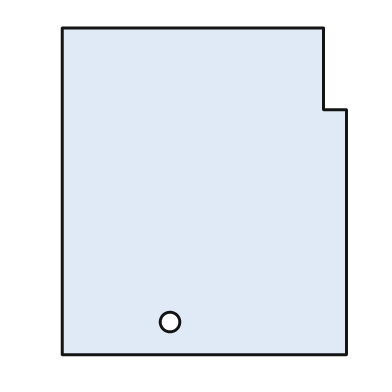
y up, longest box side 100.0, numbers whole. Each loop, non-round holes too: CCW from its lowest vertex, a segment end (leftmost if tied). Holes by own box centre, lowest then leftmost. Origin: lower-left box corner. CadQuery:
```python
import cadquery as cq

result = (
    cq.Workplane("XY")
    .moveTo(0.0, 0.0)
    .lineTo(87.0, 0.0)
    .lineTo(87.0, 75.0)
    .lineTo(80.0, 75.0)
    .lineTo(80.0, 100.0)
    .lineTo(0.0, 100.0)
    .close()
    .moveTo(33.0, 10.0)
    .circle(3.0)
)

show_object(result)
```